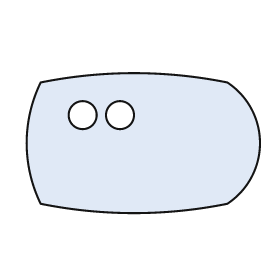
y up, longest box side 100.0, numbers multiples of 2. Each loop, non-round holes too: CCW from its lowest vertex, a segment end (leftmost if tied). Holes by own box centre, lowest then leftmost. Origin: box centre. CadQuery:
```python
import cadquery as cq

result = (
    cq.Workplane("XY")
    .moveTo(-44.0, -26.0)
    .threePointArc((-4.0, -30.0), (36.0, -26.0))
    .threePointArc((50.0, 0.0), (36.0, 26.0))
    .threePointArc((-4.0, 30.0), (-44.0, 26.0))
    .threePointArc((-50.0, 0.0), (-44.0, -26.0))
    .close()
    .moveTo(-26.0, 12.0)
    .circle(6.0)
    .moveTo(-10.0, 12.0)
    .circle(6.0)
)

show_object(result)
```